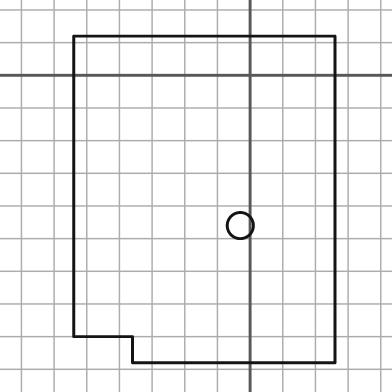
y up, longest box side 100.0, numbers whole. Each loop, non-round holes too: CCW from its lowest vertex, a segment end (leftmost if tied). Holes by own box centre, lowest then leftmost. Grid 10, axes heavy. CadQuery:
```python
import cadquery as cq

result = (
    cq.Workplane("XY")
    .moveTo(-36.0, -88.0)
    .lineTo(26.0, -88.0)
    .lineTo(26.0, 12.0)
    .lineTo(-54.0, 12.0)
    .lineTo(-54.0, -80.0)
    .lineTo(-36.0, -80.0)
    .close()
    .moveTo(-3.0, -46.0)
    .circle(4.0)
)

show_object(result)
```